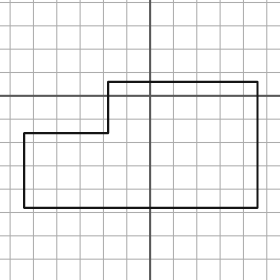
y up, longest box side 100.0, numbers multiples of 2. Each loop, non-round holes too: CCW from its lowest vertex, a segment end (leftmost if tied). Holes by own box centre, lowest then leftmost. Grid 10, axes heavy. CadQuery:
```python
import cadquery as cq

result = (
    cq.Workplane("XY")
    .moveTo(-54.0, -48.0)
    .lineTo(46.0, -48.0)
    .lineTo(46.0, 6.0)
    .lineTo(-18.0, 6.0)
    .lineTo(-18.0, -16.0)
    .lineTo(-54.0, -16.0)
    .close()
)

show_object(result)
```